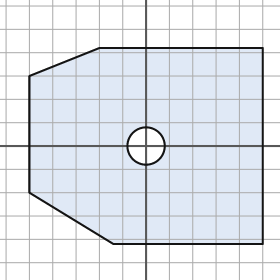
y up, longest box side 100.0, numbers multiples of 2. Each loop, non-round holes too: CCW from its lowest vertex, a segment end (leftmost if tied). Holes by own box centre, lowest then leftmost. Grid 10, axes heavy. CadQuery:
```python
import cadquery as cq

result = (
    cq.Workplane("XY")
    .moveTo(-14.0, -42.0)
    .lineTo(50.0, -42.0)
    .lineTo(50.0, 42.0)
    .lineTo(-20.0, 42.0)
    .lineTo(-50.0, 30.0)
    .lineTo(-50.0, -20.0)
    .close()
    .moveTo(0.0, 0.0)
    .circle(8.0)
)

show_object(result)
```